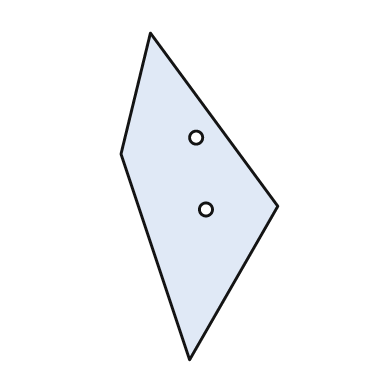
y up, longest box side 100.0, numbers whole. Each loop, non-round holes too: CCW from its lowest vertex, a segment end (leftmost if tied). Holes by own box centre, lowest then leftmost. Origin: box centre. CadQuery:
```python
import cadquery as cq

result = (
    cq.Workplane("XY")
    .moveTo(-3.0, -50.0)
    .lineTo(24.0, -3.0)
    .lineTo(-15.0, 50.0)
    .lineTo(-24.0, 13.0)
    .close()
    .moveTo(2.0, -4.0)
    .circle(2.0)
    .moveTo(-1.0, 18.0)
    .circle(2.0)
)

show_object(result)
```